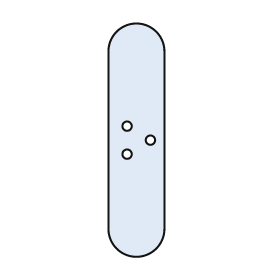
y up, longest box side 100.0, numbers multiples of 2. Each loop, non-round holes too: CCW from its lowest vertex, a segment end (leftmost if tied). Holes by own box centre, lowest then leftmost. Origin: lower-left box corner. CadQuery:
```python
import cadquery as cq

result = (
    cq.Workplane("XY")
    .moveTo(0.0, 12.0)
    .threePointArc((12.0, 0.0), (24.0, 12.0))
    .lineTo(24.0, 88.0)
    .threePointArc((12.0, 100.0), (0.0, 88.0))
    .close()
    .moveTo(8.0, 44.0)
    .circle(2.0)
    .moveTo(18.0, 50.0)
    .circle(2.0)
    .moveTo(8.0, 56.0)
    .circle(2.0)
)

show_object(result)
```